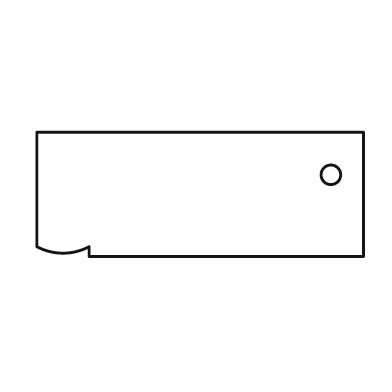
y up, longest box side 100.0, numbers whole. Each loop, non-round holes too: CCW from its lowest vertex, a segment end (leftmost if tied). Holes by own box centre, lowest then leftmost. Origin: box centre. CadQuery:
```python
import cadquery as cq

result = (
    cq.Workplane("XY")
    .moveTo(-34.0, -19.0)
    .lineTo(50.0, -19.0)
    .lineTo(50.0, 19.0)
    .lineTo(-50.0, 19.0)
    .lineTo(-50.0, -16.0)
    .threePointArc((-42.0, -18.0), (-34.0, -16.0))
    .close()
    .moveTo(40.0, 6.0)
    .circle(3.0)
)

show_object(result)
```